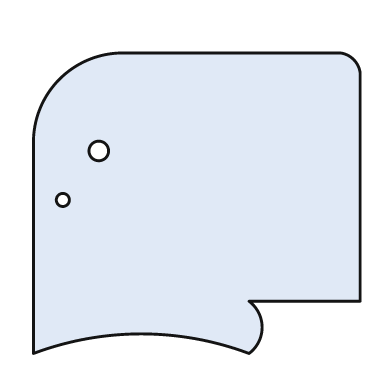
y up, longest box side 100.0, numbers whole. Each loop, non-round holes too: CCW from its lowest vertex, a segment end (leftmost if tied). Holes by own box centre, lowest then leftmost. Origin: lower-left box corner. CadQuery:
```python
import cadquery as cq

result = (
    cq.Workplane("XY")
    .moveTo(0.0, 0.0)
    .threePointArc((33.0, 6.0), (66.0, 0.0))
    .threePointArc((70.0, 8.0), (66.0, 16.0))
    .lineTo(100.0, 16.0)
    .lineTo(100.0, 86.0)
    .threePointArc((98.0, 90.0), (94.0, 92.0))
    .lineTo(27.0, 92.0)
    .threePointArc((8.0, 84.0), (0.0, 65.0))
    .close()
    .moveTo(9.0, 47.0)
    .circle(2.0)
    .moveTo(20.0, 62.0)
    .circle(3.0)
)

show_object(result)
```